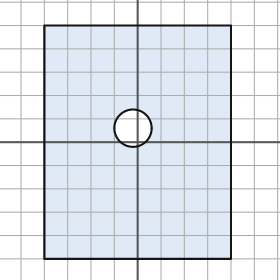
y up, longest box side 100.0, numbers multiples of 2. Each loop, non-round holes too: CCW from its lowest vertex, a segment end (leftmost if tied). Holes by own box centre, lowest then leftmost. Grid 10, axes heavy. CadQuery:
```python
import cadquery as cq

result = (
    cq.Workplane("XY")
    .moveTo(-40.0, -50.0)
    .lineTo(40.0, -50.0)
    .lineTo(40.0, 50.0)
    .lineTo(-40.0, 50.0)
    .close()
    .moveTo(-2.0, 6.0)
    .circle(8.0)
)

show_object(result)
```